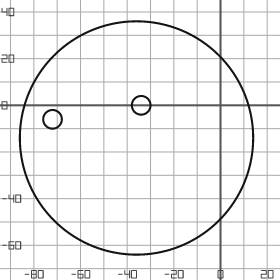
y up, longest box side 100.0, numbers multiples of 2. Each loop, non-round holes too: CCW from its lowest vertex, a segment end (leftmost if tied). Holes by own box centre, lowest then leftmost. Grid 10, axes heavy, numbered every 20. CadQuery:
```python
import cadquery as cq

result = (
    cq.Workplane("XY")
    .moveTo(-36.0, -14.0)
    .circle(50.0)
    .moveTo(-72.0, -6.0)
    .circle(4.0)
    .moveTo(-34.0, 0.0)
    .circle(4.0)
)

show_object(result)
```